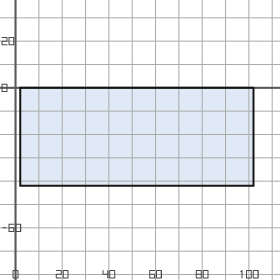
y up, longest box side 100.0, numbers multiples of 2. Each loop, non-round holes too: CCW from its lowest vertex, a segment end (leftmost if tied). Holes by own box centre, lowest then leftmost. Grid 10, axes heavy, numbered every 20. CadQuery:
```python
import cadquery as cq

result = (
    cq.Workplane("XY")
    .moveTo(2.0, -42.0)
    .lineTo(102.0, -42.0)
    .lineTo(102.0, 0.0)
    .lineTo(2.0, 0.0)
    .close()
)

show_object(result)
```